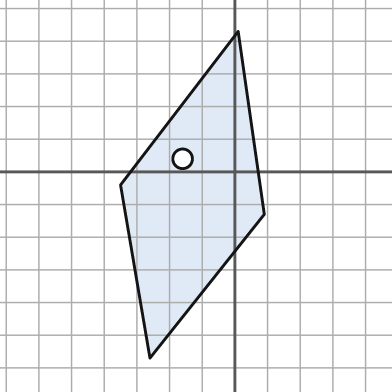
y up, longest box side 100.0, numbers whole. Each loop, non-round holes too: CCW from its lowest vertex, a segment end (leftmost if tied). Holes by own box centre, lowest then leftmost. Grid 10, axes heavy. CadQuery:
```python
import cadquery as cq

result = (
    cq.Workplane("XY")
    .moveTo(-26.0, -57.0)
    .lineTo(9.0, -13.0)
    .lineTo(1.0, 43.0)
    .lineTo(-35.0, -4.0)
    .close()
    .moveTo(-16.0, 4.0)
    .circle(3.0)
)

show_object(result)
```